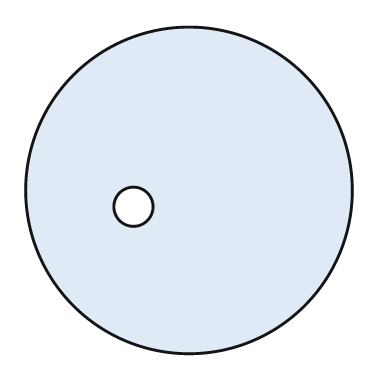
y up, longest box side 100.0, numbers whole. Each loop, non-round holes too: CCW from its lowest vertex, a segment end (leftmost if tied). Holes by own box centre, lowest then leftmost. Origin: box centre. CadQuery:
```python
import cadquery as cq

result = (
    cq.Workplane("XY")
    .moveTo(0.0, 0.0)
    .circle(50.0)
    .moveTo(-17.0, -5.0)
    .circle(6.0)
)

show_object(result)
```